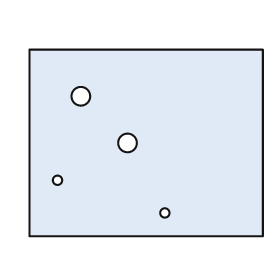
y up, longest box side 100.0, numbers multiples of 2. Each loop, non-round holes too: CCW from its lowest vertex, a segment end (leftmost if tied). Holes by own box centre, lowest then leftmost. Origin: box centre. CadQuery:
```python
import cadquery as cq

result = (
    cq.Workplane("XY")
    .moveTo(-50.0, -40.0)
    .lineTo(50.0, -40.0)
    .lineTo(50.0, 40.0)
    .lineTo(-50.0, 40.0)
    .close()
    .moveTo(8.0, -30.0)
    .circle(2.0)
    .moveTo(-38.0, -16.0)
    .circle(2.0)
    .moveTo(-8.0, 0.0)
    .circle(4.0)
    .moveTo(-28.0, 20.0)
    .circle(4.0)
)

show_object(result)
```